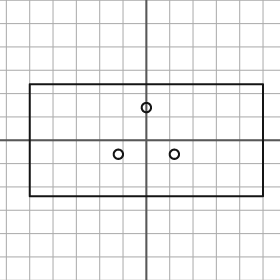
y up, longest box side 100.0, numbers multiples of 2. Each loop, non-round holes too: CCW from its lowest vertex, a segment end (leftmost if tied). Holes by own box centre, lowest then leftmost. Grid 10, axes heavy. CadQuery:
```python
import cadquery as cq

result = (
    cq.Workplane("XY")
    .moveTo(-50.0, -24.0)
    .lineTo(50.0, -24.0)
    .lineTo(50.0, 24.0)
    .lineTo(-50.0, 24.0)
    .close()
    .moveTo(-12.0, -6.0)
    .circle(2.0)
    .moveTo(12.0, -6.0)
    .circle(2.0)
    .moveTo(0.0, 14.0)
    .circle(2.0)
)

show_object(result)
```